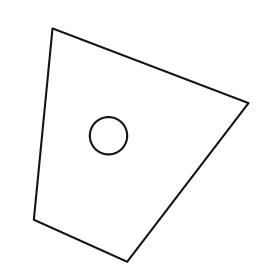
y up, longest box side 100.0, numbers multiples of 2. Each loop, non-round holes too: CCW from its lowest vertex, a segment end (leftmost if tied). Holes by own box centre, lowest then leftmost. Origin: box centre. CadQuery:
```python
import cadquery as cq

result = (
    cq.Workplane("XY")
    .moveTo(-6.0, -50.0)
    .lineTo(46.0, 18.0)
    .lineTo(-38.0, 50.0)
    .lineTo(-46.0, -32.0)
    .close()
    .moveTo(-14.0, 4.0)
    .circle(8.0)
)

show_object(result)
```